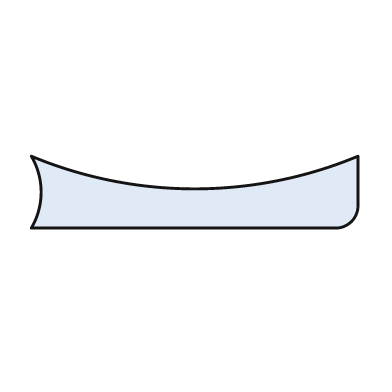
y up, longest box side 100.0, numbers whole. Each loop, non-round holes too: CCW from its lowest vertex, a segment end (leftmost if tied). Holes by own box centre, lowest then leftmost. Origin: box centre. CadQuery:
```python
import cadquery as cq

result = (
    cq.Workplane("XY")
    .moveTo(-50.0, -11.0)
    .lineTo(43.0, -11.0)
    .threePointArc((48.0, -9.0), (50.0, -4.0))
    .lineTo(50.0, 11.0)
    .threePointArc((0.0, 1.0), (-50.0, 11.0))
    .threePointArc((-47.0, 0.0), (-50.0, -11.0))
    .close()
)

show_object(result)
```